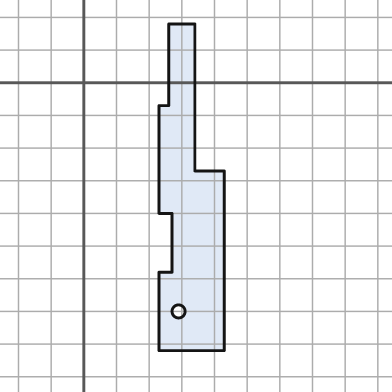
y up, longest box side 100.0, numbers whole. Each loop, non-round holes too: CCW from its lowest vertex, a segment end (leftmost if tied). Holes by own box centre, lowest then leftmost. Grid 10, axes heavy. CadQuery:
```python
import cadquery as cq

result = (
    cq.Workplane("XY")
    .moveTo(23.0, -82.0)
    .lineTo(43.0, -82.0)
    .lineTo(43.0, -27.0)
    .lineTo(34.0, -27.0)
    .lineTo(34.0, 18.0)
    .lineTo(26.0, 18.0)
    .lineTo(26.0, -7.0)
    .lineTo(23.0, -7.0)
    .lineTo(23.0, -40.0)
    .lineTo(27.0, -40.0)
    .lineTo(27.0, -58.0)
    .lineTo(23.0, -58.0)
    .close()
    .moveTo(29.0, -70.0)
    .circle(2.0)
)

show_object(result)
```